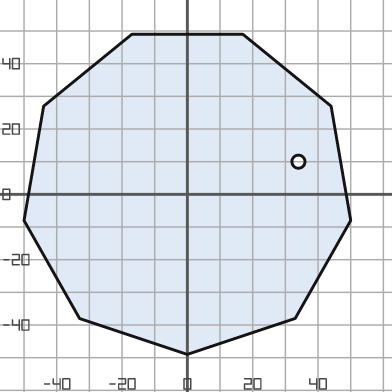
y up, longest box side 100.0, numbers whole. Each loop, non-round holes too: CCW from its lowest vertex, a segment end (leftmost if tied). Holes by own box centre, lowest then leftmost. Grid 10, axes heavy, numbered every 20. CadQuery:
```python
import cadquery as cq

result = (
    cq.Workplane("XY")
    .moveTo(0.0, -49.0)
    .lineTo(33.0, -38.0)
    .lineTo(50.0, -8.0)
    .lineTo(44.0, 27.0)
    .lineTo(17.0, 49.0)
    .lineTo(-17.0, 49.0)
    .lineTo(-44.0, 27.0)
    .lineTo(-50.0, -8.0)
    .lineTo(-33.0, -38.0)
    .close()
    .moveTo(34.0, 10.0)
    .circle(2.0)
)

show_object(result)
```